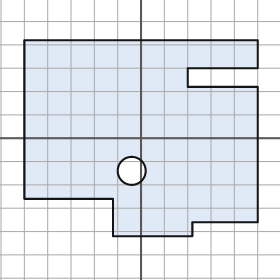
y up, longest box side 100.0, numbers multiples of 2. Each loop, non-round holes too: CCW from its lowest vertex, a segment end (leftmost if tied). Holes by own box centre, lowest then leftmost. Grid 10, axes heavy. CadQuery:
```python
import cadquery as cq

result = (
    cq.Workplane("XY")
    .moveTo(-12.0, -42.0)
    .lineTo(22.0, -42.0)
    .lineTo(22.0, -36.0)
    .lineTo(50.0, -36.0)
    .lineTo(50.0, 22.0)
    .lineTo(20.0, 22.0)
    .lineTo(20.0, 30.0)
    .lineTo(50.0, 30.0)
    .lineTo(50.0, 42.0)
    .lineTo(-50.0, 42.0)
    .lineTo(-50.0, -26.0)
    .lineTo(-12.0, -26.0)
    .close()
    .moveTo(-4.0, -14.0)
    .circle(6.0)
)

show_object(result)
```